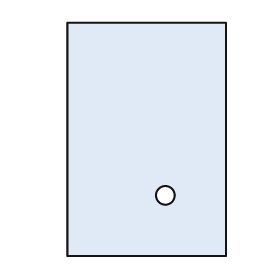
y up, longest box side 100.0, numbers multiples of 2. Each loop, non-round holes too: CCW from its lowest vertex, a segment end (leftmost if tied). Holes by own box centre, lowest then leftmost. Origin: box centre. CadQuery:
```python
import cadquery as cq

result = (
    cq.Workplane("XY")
    .moveTo(-34.0, -50.0)
    .lineTo(34.0, -50.0)
    .lineTo(34.0, 50.0)
    .lineTo(-34.0, 50.0)
    .close()
    .moveTo(8.0, -24.0)
    .circle(4.0)
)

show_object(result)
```